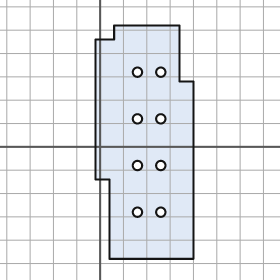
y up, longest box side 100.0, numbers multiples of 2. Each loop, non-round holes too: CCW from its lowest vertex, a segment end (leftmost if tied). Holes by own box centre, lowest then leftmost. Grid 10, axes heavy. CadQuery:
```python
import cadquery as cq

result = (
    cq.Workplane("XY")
    .moveTo(4.0, -48.0)
    .lineTo(40.0, -48.0)
    .lineTo(40.0, 28.0)
    .lineTo(34.0, 28.0)
    .lineTo(34.0, 52.0)
    .lineTo(6.0, 52.0)
    .lineTo(6.0, 46.0)
    .lineTo(-2.0, 46.0)
    .lineTo(-2.0, -14.0)
    .lineTo(4.0, -14.0)
    .close()
    .moveTo(16.0, -28.0)
    .circle(2.0)
    .moveTo(26.0, -28.0)
    .circle(2.0)
    .moveTo(16.0, -8.0)
    .circle(2.0)
    .moveTo(26.0, -8.0)
    .circle(2.0)
    .moveTo(16.0, 12.0)
    .circle(2.0)
    .moveTo(26.0, 12.0)
    .circle(2.0)
    .moveTo(16.0, 32.0)
    .circle(2.0)
    .moveTo(26.0, 32.0)
    .circle(2.0)
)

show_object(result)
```